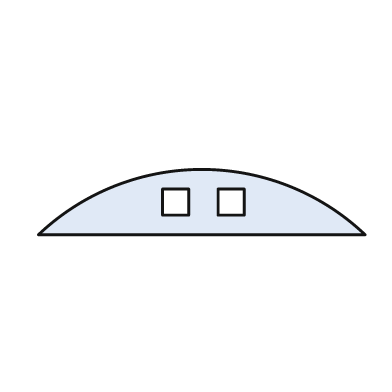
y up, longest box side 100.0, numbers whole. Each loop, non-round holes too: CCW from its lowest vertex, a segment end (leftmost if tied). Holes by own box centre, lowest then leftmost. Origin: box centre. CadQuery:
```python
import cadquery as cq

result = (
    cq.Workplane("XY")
    .moveTo(-50.0, -10.0)
    .lineTo(50.0, -10.0)
    .threePointArc((0.0, 10.0), (-50.0, -10.0))
    .close()
    .moveTo(-12.0, -4.0)
    .lineTo(-4.0, -4.0)
    .lineTo(-4.0, 4.0)
    .lineTo(-12.0, 4.0)
    .close()
    .moveTo(5.0, -4.0)
    .lineTo(13.0, -4.0)
    .lineTo(13.0, 4.0)
    .lineTo(5.0, 4.0)
    .close()
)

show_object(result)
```